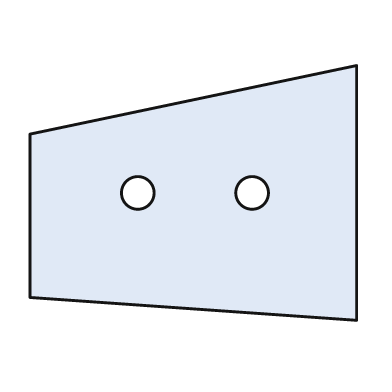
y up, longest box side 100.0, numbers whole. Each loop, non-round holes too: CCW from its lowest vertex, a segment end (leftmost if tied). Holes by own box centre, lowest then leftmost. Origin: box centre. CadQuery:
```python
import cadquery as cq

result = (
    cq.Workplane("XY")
    .moveTo(50.0, -39.0)
    .lineTo(50.0, 39.0)
    .lineTo(-50.0, 18.0)
    .lineTo(-50.0, -32.0)
    .close()
    .moveTo(-17.0, 0.0)
    .circle(5.0)
    .moveTo(18.0, 0.0)
    .circle(5.0)
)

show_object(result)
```